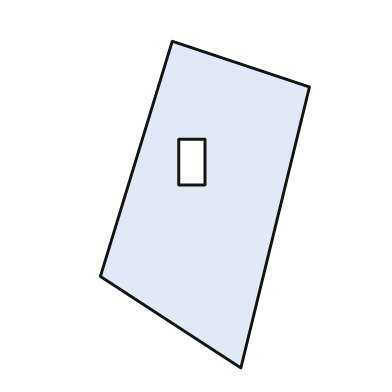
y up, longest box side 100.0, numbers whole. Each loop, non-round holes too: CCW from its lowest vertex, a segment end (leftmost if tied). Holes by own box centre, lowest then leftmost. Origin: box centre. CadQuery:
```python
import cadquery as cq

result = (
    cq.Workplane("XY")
    .moveTo(11.0, -50.0)
    .lineTo(32.0, 36.0)
    .lineTo(-10.0, 50.0)
    .lineTo(-32.0, -22.0)
    .close()
    .moveTo(-8.0, 6.0)
    .lineTo(0.0, 6.0)
    .lineTo(0.0, 20.0)
    .lineTo(-8.0, 20.0)
    .close()
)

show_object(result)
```